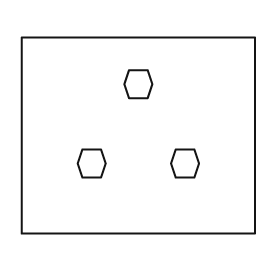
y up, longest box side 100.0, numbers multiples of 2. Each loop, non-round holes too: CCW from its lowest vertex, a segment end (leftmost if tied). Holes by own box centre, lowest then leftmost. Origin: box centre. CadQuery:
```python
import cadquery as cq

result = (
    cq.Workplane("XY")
    .moveTo(-50.0, -42.0)
    .lineTo(50.0, -42.0)
    .lineTo(50.0, 42.0)
    .lineTo(-50.0, 42.0)
    .close()
    .moveTo(-24.0, -18.0)
    .lineTo(-16.0, -18.0)
    .lineTo(-14.0, -12.0)
    .lineTo(-16.0, -6.0)
    .lineTo(-24.0, -6.0)
    .lineTo(-26.0, -12.0)
    .close()
    .moveTo(16.0, -18.0)
    .lineTo(24.0, -18.0)
    .lineTo(26.0, -12.0)
    .lineTo(24.0, -6.0)
    .lineTo(16.0, -6.0)
    .lineTo(14.0, -12.0)
    .close()
    .moveTo(-4.0, 16.0)
    .lineTo(4.0, 16.0)
    .lineTo(6.0, 22.0)
    .lineTo(4.0, 28.0)
    .lineTo(-4.0, 28.0)
    .lineTo(-6.0, 22.0)
    .close()
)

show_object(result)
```